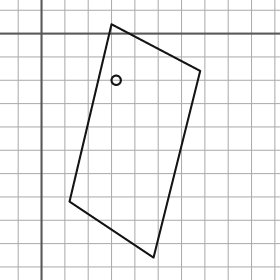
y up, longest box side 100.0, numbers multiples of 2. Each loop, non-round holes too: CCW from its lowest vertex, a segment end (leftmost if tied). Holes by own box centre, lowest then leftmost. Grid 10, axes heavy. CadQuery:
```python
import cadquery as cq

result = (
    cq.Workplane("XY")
    .moveTo(48.0, -96.0)
    .lineTo(68.0, -16.0)
    .lineTo(30.0, 4.0)
    .lineTo(12.0, -72.0)
    .close()
    .moveTo(32.0, -20.0)
    .circle(2.0)
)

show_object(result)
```